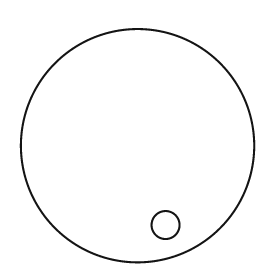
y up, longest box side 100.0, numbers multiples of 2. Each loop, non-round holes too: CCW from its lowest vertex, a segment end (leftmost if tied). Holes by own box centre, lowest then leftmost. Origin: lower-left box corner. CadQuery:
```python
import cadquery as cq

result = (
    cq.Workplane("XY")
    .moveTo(50.0, 50.0)
    .circle(50.0)
    .moveTo(62.0, 16.0)
    .circle(6.0)
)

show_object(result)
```